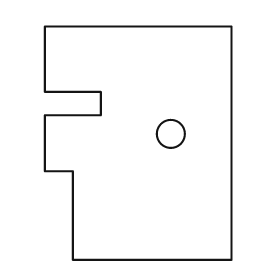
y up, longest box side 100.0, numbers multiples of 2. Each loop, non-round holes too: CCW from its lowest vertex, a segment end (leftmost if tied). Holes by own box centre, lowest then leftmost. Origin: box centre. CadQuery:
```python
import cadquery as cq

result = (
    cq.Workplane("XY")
    .moveTo(-28.0, -50.0)
    .lineTo(40.0, -50.0)
    .lineTo(40.0, 50.0)
    .lineTo(-40.0, 50.0)
    .lineTo(-40.0, 22.0)
    .lineTo(-16.0, 22.0)
    .lineTo(-16.0, 12.0)
    .lineTo(-40.0, 12.0)
    .lineTo(-40.0, -12.0)
    .lineTo(-28.0, -12.0)
    .close()
    .moveTo(14.0, 4.0)
    .circle(6.0)
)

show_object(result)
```